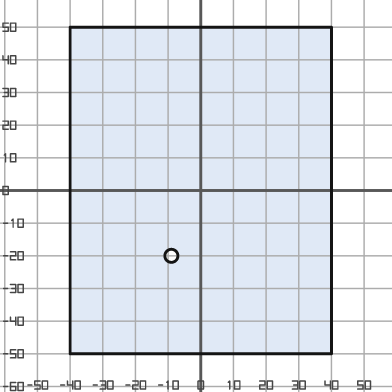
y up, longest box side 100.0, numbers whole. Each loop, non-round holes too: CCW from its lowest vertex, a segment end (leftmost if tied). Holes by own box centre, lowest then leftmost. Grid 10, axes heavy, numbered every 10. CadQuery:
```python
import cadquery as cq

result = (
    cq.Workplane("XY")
    .moveTo(-40.0, -50.0)
    .lineTo(40.0, -50.0)
    .lineTo(40.0, 50.0)
    .lineTo(-40.0, 50.0)
    .close()
    .moveTo(-9.0, -20.0)
    .circle(2.0)
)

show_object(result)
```